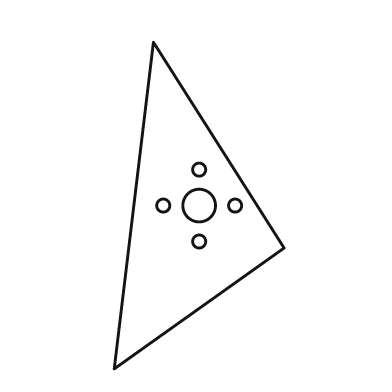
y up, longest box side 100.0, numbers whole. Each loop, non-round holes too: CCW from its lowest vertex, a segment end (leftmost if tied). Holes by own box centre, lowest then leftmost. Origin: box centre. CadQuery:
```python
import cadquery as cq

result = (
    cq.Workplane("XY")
    .moveTo(-26.0, -50.0)
    .lineTo(26.0, -13.0)
    .lineTo(-14.0, 50.0)
    .close()
    .moveTo(0.0, -11.0)
    .circle(2.0)
    .moveTo(-11.0, 0.0)
    .circle(2.0)
    .moveTo(0.0, 0.0)
    .circle(5.0)
    .moveTo(11.0, 0.0)
    .circle(2.0)
    .moveTo(0.0, 11.0)
    .circle(2.0)
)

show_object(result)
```